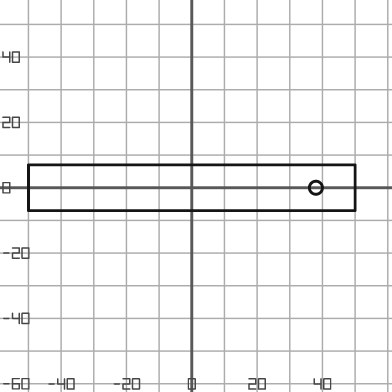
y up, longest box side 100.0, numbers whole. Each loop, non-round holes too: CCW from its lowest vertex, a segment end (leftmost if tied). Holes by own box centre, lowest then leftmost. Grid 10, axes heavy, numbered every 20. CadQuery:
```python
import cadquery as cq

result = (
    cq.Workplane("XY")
    .moveTo(-50.0, -7.0)
    .lineTo(50.0, -7.0)
    .lineTo(50.0, 7.0)
    .lineTo(-50.0, 7.0)
    .close()
    .moveTo(38.0, 0.0)
    .circle(2.0)
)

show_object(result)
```